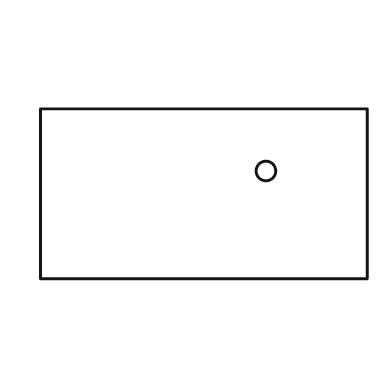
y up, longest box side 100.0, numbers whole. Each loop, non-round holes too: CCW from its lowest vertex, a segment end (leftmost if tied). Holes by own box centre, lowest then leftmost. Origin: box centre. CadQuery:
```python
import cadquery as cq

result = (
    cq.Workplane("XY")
    .moveTo(-50.0, -26.0)
    .lineTo(50.0, -26.0)
    .lineTo(50.0, 26.0)
    .lineTo(-50.0, 26.0)
    .close()
    .moveTo(19.0, 7.0)
    .circle(3.0)
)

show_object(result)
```